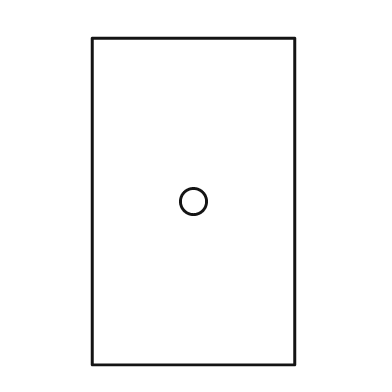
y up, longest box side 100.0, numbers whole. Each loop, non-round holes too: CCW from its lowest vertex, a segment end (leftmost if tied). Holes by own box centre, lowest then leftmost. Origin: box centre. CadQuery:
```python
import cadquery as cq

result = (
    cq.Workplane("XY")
    .moveTo(-31.0, -50.0)
    .lineTo(31.0, -50.0)
    .lineTo(31.0, 50.0)
    .lineTo(-31.0, 50.0)
    .close()
    .moveTo(0.0, 0.0)
    .circle(4.0)
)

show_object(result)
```